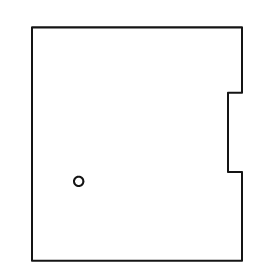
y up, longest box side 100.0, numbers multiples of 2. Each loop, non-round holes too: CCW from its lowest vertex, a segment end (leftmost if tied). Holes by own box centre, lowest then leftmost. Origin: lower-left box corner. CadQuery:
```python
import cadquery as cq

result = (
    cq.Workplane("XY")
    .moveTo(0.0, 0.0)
    .lineTo(90.0, 0.0)
    .lineTo(90.0, 38.0)
    .lineTo(84.0, 38.0)
    .lineTo(84.0, 72.0)
    .lineTo(90.0, 72.0)
    .lineTo(90.0, 100.0)
    .lineTo(0.0, 100.0)
    .close()
    .moveTo(20.0, 34.0)
    .circle(2.0)
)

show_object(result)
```